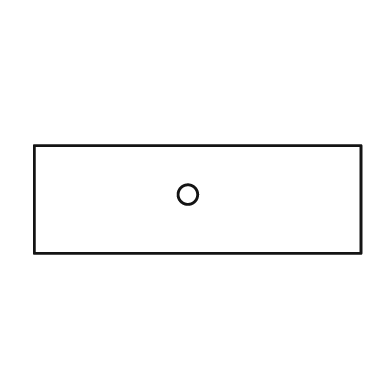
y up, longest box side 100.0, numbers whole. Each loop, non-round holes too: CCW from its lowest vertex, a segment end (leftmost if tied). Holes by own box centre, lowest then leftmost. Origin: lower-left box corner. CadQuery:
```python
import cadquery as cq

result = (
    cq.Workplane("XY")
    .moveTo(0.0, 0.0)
    .lineTo(100.0, 0.0)
    .lineTo(100.0, 33.0)
    .lineTo(0.0, 33.0)
    .close()
    .moveTo(47.0, 18.0)
    .circle(3.0)
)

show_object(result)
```